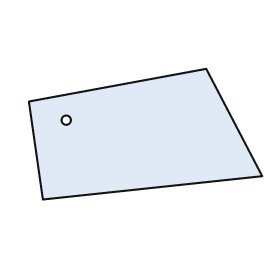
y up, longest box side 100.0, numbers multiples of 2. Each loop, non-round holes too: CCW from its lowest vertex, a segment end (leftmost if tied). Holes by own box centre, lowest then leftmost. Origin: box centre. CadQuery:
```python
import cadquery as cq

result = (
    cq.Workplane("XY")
    .moveTo(-44.0, -28.0)
    .lineTo(50.0, -18.0)
    .lineTo(26.0, 28.0)
    .lineTo(-50.0, 14.0)
    .close()
    .moveTo(-34.0, 6.0)
    .circle(2.0)
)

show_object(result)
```